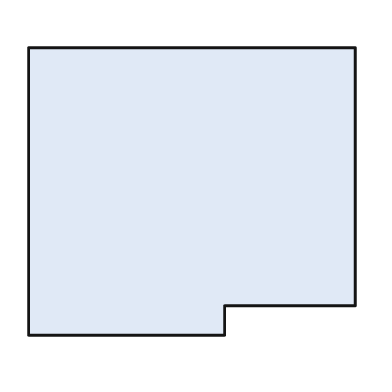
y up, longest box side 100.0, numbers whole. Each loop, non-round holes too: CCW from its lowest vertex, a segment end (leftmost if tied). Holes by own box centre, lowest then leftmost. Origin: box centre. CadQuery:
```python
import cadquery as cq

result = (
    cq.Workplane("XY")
    .moveTo(-50.0, -44.0)
    .lineTo(10.0, -44.0)
    .lineTo(10.0, -35.0)
    .lineTo(50.0, -35.0)
    .lineTo(50.0, 44.0)
    .lineTo(-50.0, 44.0)
    .close()
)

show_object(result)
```